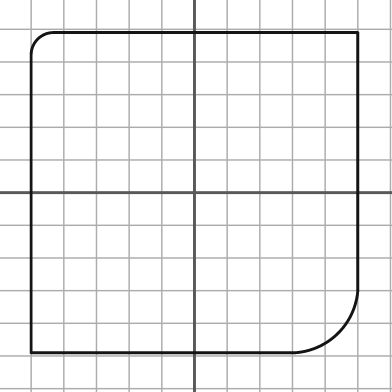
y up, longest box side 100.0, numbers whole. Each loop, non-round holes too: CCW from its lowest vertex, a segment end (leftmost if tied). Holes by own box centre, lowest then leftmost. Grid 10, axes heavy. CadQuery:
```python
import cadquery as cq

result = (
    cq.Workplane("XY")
    .moveTo(-50.0, -49.0)
    .lineTo(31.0, -49.0)
    .threePointArc((44.0, -43.0), (50.0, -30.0))
    .lineTo(50.0, 49.0)
    .lineTo(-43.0, 49.0)
    .threePointArc((-48.0, 47.0), (-50.0, 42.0))
    .close()
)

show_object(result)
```